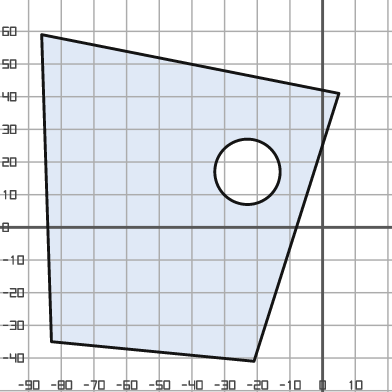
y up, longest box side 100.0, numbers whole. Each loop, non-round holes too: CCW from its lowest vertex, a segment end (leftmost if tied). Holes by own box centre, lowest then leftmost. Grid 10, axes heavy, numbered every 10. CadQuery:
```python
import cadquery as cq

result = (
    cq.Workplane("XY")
    .moveTo(-21.0, -41.0)
    .lineTo(5.0, 41.0)
    .lineTo(-86.0, 59.0)
    .lineTo(-83.0, -35.0)
    .close()
    .moveTo(-23.0, 17.0)
    .circle(10.0)
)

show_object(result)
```